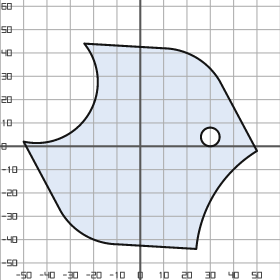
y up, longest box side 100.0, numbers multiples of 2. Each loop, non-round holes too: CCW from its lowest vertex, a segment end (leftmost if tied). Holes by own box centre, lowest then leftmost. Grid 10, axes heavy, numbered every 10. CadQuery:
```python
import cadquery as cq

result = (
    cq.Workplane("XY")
    .moveTo(24.0, -44.0)
    .threePointArc((32.0, -20.0), (50.0, -2.0))
    .lineTo(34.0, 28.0)
    .threePointArc((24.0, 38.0), (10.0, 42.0))
    .lineTo(-24.0, 44.0)
    .threePointArc((-22.0, 14.0), (-50.0, 2.0))
    .lineTo(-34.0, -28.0)
    .threePointArc((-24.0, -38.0), (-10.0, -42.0))
    .close()
    .moveTo(30.0, 4.0)
    .circle(4.0)
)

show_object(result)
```